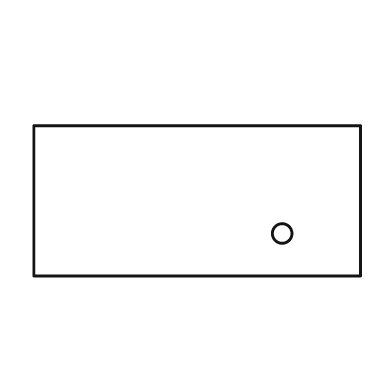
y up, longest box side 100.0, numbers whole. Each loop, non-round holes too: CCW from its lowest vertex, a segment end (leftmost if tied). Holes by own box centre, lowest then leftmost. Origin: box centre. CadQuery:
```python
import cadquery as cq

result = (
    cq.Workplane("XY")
    .moveTo(-50.0, -23.0)
    .lineTo(50.0, -23.0)
    .lineTo(50.0, 23.0)
    .lineTo(-50.0, 23.0)
    .close()
    .moveTo(26.0, -10.0)
    .circle(3.0)
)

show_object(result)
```